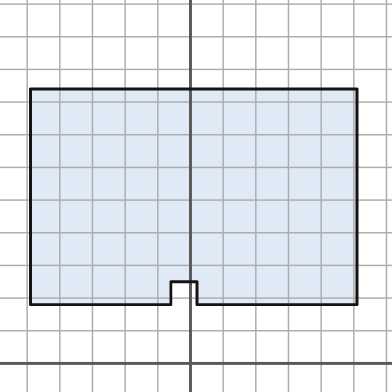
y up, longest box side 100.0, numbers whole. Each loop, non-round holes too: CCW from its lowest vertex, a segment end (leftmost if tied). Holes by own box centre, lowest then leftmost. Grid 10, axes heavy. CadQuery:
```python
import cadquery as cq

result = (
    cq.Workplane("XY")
    .moveTo(-49.0, 18.0)
    .lineTo(-6.0, 18.0)
    .lineTo(-6.0, 25.0)
    .lineTo(2.0, 25.0)
    .lineTo(2.0, 18.0)
    .lineTo(51.0, 18.0)
    .lineTo(51.0, 84.0)
    .lineTo(-49.0, 84.0)
    .close()
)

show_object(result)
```